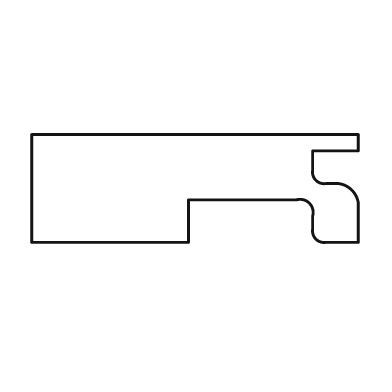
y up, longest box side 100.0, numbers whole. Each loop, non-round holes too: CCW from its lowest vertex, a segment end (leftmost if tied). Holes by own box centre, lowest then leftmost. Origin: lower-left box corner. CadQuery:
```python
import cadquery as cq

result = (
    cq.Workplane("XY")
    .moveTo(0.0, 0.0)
    .lineTo(48.0, 0.0)
    .lineTo(48.0, 13.0)
    .lineTo(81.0, 13.0)
    .threePointArc((85.0, 12.0), (86.0, 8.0))
    .lineTo(86.0, 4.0)
    .threePointArc((87.0, 1.0), (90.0, 0.0))
    .lineTo(100.0, 0.0)
    .lineTo(100.0, 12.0)
    .threePointArc((98.0, 16.0), (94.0, 18.0))
    .lineTo(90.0, 18.0)
    .threePointArc((87.0, 19.0), (86.0, 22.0))
    .lineTo(86.0, 28.0)
    .lineTo(100.0, 28.0)
    .lineTo(100.0, 33.0)
    .lineTo(0.0, 33.0)
    .close()
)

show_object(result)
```